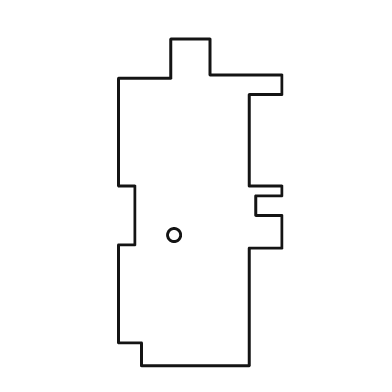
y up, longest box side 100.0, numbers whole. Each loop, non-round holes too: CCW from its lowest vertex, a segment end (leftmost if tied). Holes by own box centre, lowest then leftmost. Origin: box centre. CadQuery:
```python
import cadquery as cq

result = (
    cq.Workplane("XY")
    .moveTo(-18.0, -50.0)
    .lineTo(15.0, -50.0)
    .lineTo(15.0, -14.0)
    .lineTo(25.0, -14.0)
    .lineTo(25.0, -4.0)
    .lineTo(17.0, -4.0)
    .lineTo(17.0, 2.0)
    .lineTo(25.0, 2.0)
    .lineTo(25.0, 5.0)
    .lineTo(15.0, 5.0)
    .lineTo(15.0, 33.0)
    .lineTo(25.0, 33.0)
    .lineTo(25.0, 39.0)
    .lineTo(3.0, 39.0)
    .lineTo(3.0, 50.0)
    .lineTo(-9.0, 50.0)
    .lineTo(-9.0, 38.0)
    .lineTo(-25.0, 38.0)
    .lineTo(-25.0, 5.0)
    .lineTo(-20.0, 5.0)
    .lineTo(-20.0, -13.0)
    .lineTo(-25.0, -13.0)
    .lineTo(-25.0, -43.0)
    .lineTo(-18.0, -43.0)
    .close()
    .moveTo(-8.0, -10.0)
    .circle(2.0)
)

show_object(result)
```